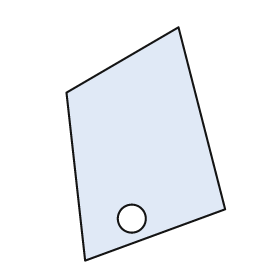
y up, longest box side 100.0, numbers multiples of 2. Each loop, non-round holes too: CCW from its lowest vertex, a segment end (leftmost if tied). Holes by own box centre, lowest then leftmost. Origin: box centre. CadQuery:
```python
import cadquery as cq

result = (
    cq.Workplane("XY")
    .moveTo(-26.0, -50.0)
    .lineTo(34.0, -28.0)
    .lineTo(14.0, 50.0)
    .lineTo(-34.0, 22.0)
    .close()
    .moveTo(-6.0, -32.0)
    .circle(6.0)
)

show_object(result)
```